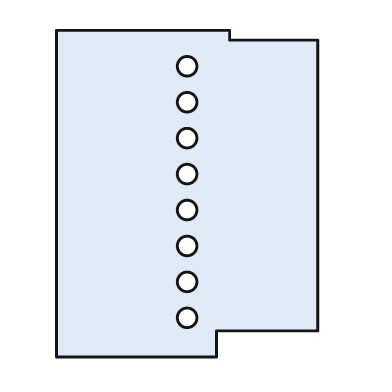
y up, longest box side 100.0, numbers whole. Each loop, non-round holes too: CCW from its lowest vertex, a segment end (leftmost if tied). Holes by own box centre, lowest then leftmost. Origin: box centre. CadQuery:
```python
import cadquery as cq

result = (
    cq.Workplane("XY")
    .moveTo(-40.0, -50.0)
    .lineTo(9.0, -50.0)
    .lineTo(9.0, -42.0)
    .lineTo(40.0, -42.0)
    .lineTo(40.0, 47.0)
    .lineTo(13.0, 47.0)
    .lineTo(13.0, 50.0)
    .lineTo(-40.0, 50.0)
    .close()
    .moveTo(0.0, -38.0)
    .circle(3.0)
    .moveTo(0.0, -27.0)
    .circle(3.0)
    .moveTo(0.0, -16.0)
    .circle(3.0)
    .moveTo(0.0, -5.0)
    .circle(3.0)
    .moveTo(0.0, 6.0)
    .circle(3.0)
    .moveTo(0.0, 17.0)
    .circle(3.0)
    .moveTo(0.0, 28.0)
    .circle(3.0)
    .moveTo(0.0, 39.0)
    .circle(3.0)
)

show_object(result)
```